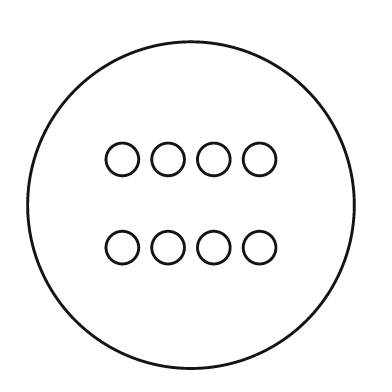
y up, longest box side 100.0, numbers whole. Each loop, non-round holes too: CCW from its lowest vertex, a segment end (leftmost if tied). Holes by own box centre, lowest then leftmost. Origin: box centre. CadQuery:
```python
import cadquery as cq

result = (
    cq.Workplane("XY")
    .moveTo(0.0, 0.0)
    .circle(50.0)
    .moveTo(-21.0, -13.0)
    .circle(5.0)
    .moveTo(-7.0, -13.0)
    .circle(5.0)
    .moveTo(7.0, -13.0)
    .circle(5.0)
    .moveTo(21.0, -13.0)
    .circle(5.0)
    .moveTo(-21.0, 14.0)
    .circle(5.0)
    .moveTo(-7.0, 14.0)
    .circle(5.0)
    .moveTo(7.0, 14.0)
    .circle(5.0)
    .moveTo(21.0, 14.0)
    .circle(5.0)
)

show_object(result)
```